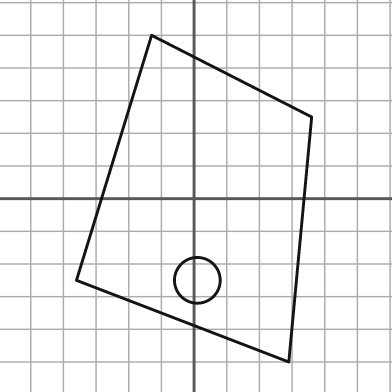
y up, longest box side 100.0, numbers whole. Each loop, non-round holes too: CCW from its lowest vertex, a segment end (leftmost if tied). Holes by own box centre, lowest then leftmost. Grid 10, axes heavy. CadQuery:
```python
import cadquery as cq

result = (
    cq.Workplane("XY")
    .moveTo(29.0, -50.0)
    .lineTo(36.0, 25.0)
    .lineTo(-13.0, 50.0)
    .lineTo(-36.0, -25.0)
    .close()
    .moveTo(1.0, -25.0)
    .circle(7.0)
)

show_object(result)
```